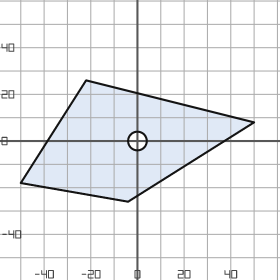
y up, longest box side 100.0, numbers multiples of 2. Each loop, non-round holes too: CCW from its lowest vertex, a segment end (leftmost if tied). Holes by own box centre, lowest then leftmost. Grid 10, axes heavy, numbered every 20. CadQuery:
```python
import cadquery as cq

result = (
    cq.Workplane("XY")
    .moveTo(-4.0, -26.0)
    .lineTo(50.0, 8.0)
    .lineTo(-22.0, 26.0)
    .lineTo(-50.0, -18.0)
    .close()
    .moveTo(0.0, 0.0)
    .circle(4.0)
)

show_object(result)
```